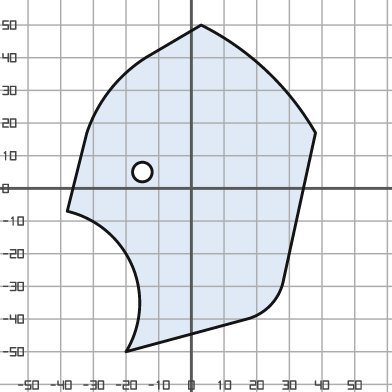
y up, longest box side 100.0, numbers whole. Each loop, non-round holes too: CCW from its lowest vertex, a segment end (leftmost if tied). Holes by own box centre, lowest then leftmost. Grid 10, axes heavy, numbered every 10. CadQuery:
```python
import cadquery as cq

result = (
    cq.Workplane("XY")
    .moveTo(-20.0, -50.0)
    .lineTo(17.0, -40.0)
    .threePointArc((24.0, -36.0), (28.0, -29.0))
    .lineTo(38.0, 17.0)
    .threePointArc((23.0, 36.0), (3.0, 50.0))
    .lineTo(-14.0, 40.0)
    .threePointArc((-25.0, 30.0), (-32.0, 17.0))
    .lineTo(-38.0, -7.0)
    .threePointArc((-18.0, -24.0), (-20.0, -50.0))
    .close()
    .moveTo(-15.0, 5.0)
    .circle(3.0)
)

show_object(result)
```